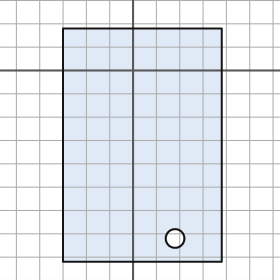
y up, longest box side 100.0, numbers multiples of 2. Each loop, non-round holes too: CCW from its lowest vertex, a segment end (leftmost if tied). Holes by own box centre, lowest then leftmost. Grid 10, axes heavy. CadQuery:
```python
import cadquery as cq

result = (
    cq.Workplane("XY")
    .moveTo(-30.0, -82.0)
    .lineTo(38.0, -82.0)
    .lineTo(38.0, 18.0)
    .lineTo(-30.0, 18.0)
    .close()
    .moveTo(18.0, -72.0)
    .circle(4.0)
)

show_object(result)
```